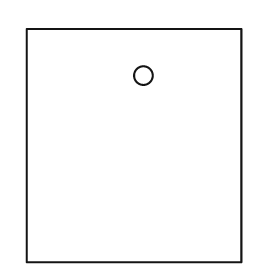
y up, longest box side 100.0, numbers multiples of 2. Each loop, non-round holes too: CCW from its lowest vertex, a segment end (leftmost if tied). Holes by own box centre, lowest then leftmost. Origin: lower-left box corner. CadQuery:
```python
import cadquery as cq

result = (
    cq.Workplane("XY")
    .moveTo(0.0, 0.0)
    .lineTo(92.0, 0.0)
    .lineTo(92.0, 100.0)
    .lineTo(0.0, 100.0)
    .close()
    .moveTo(50.0, 80.0)
    .circle(4.0)
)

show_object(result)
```